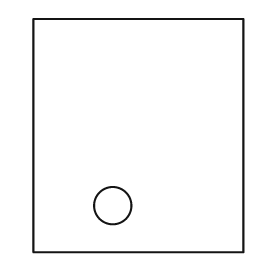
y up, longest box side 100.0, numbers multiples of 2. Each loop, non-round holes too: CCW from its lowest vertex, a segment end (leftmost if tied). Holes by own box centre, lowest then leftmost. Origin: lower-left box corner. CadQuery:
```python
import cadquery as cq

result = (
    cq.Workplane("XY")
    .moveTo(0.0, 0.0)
    .lineTo(90.0, 0.0)
    .lineTo(90.0, 100.0)
    .lineTo(0.0, 100.0)
    .close()
    .moveTo(34.0, 20.0)
    .circle(8.0)
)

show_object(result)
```